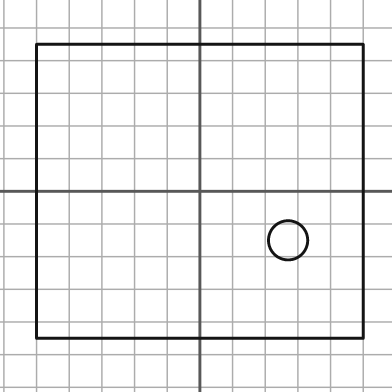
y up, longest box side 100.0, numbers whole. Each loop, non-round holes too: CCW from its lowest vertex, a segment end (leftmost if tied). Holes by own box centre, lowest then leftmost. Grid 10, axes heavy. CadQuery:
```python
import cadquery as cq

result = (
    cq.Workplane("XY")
    .moveTo(-50.0, -45.0)
    .lineTo(50.0, -45.0)
    .lineTo(50.0, 45.0)
    .lineTo(-50.0, 45.0)
    .close()
    .moveTo(27.0, -15.0)
    .circle(6.0)
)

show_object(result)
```